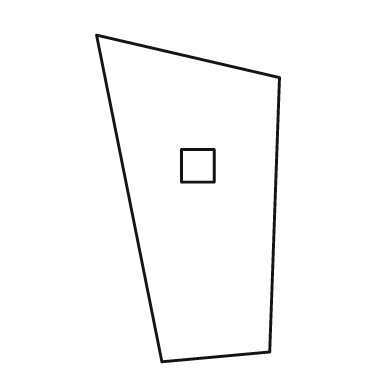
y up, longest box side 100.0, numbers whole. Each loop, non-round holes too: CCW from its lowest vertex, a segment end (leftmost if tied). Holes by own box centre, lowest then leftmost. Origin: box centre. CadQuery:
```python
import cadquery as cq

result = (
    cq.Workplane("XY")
    .moveTo(-8.0, -50.0)
    .lineTo(25.0, -47.0)
    .lineTo(28.0, 37.0)
    .lineTo(-28.0, 50.0)
    .close()
    .moveTo(-2.0, 5.0)
    .lineTo(8.0, 5.0)
    .lineTo(8.0, 15.0)
    .lineTo(-2.0, 15.0)
    .close()
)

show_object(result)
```